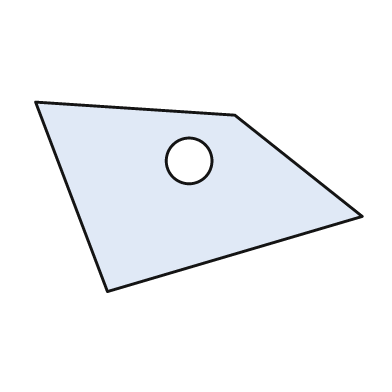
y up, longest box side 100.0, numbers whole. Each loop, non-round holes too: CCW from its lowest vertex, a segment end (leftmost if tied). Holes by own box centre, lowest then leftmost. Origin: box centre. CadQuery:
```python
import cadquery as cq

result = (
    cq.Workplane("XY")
    .moveTo(-28.0, -29.0)
    .lineTo(50.0, -6.0)
    .lineTo(11.0, 25.0)
    .lineTo(-50.0, 29.0)
    .close()
    .moveTo(-3.0, 11.0)
    .circle(7.0)
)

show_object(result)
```